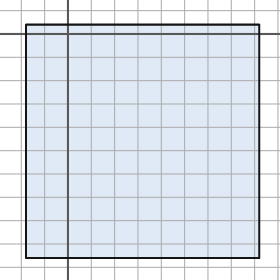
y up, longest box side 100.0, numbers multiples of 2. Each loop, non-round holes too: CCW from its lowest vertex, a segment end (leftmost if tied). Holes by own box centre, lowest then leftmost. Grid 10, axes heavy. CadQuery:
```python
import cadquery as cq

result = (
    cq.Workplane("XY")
    .moveTo(-18.0, -96.0)
    .lineTo(82.0, -96.0)
    .lineTo(82.0, 4.0)
    .lineTo(-18.0, 4.0)
    .close()
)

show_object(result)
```